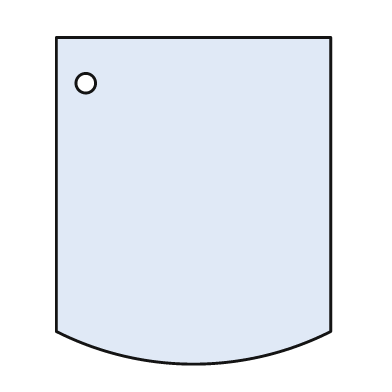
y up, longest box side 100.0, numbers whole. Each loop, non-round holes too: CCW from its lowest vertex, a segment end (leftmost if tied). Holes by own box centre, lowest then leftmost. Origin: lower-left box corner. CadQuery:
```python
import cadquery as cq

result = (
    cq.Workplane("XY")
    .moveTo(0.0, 10.0)
    .threePointArc((42.0, 0.0), (84.0, 10.0))
    .lineTo(84.0, 100.0)
    .lineTo(0.0, 100.0)
    .close()
    .moveTo(9.0, 86.0)
    .circle(3.0)
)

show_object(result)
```